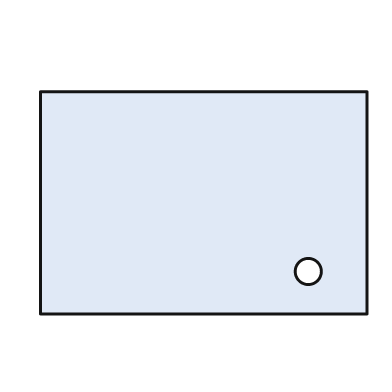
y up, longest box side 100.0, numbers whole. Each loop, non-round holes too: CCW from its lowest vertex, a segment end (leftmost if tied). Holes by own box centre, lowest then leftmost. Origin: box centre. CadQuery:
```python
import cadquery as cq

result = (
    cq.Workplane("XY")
    .moveTo(-50.0, -34.0)
    .lineTo(50.0, -34.0)
    .lineTo(50.0, 34.0)
    .lineTo(-50.0, 34.0)
    .close()
    .moveTo(32.0, -21.0)
    .circle(4.0)
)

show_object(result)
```